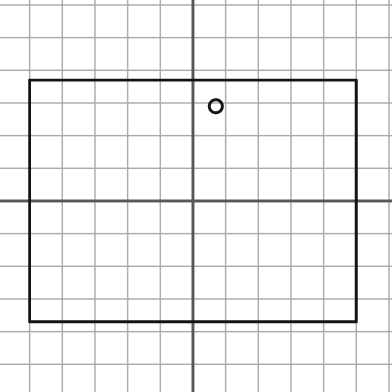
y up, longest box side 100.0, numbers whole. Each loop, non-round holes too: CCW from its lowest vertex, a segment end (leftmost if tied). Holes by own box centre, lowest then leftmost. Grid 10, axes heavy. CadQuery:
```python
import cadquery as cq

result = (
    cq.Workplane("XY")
    .moveTo(-50.0, -37.0)
    .lineTo(50.0, -37.0)
    .lineTo(50.0, 37.0)
    .lineTo(-50.0, 37.0)
    .close()
    .moveTo(7.0, 29.0)
    .circle(2.0)
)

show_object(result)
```